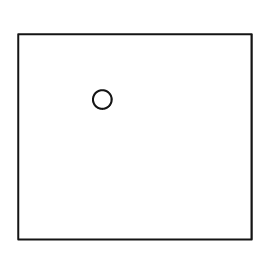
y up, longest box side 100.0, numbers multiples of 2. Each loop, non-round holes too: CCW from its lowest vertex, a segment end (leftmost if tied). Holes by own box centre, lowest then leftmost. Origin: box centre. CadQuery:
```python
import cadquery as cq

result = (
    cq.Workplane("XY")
    .moveTo(-50.0, -44.0)
    .lineTo(50.0, -44.0)
    .lineTo(50.0, 44.0)
    .lineTo(-50.0, 44.0)
    .close()
    .moveTo(-14.0, 16.0)
    .circle(4.0)
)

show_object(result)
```